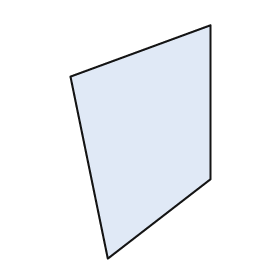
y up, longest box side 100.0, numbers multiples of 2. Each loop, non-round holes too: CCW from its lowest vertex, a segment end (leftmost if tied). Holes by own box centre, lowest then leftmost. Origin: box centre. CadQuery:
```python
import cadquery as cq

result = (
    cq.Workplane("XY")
    .moveTo(-14.0, -50.0)
    .lineTo(30.0, -16.0)
    .lineTo(30.0, 50.0)
    .lineTo(-30.0, 28.0)
    .close()
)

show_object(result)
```